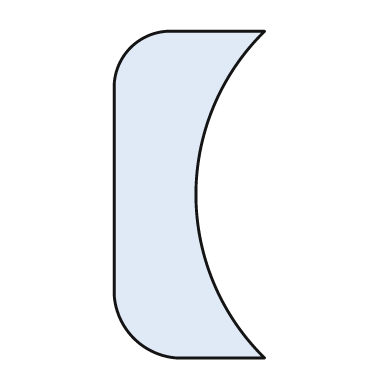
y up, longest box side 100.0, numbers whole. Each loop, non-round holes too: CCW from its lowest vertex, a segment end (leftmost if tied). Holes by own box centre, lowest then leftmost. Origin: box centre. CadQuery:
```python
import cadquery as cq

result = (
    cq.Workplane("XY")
    .moveTo(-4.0, -50.0)
    .lineTo(23.0, -50.0)
    .threePointArc((2.0, 0.0), (23.0, 50.0))
    .lineTo(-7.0, 50.0)
    .threePointArc((-18.0, 45.0), (-23.0, 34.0))
    .lineTo(-23.0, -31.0)
    .threePointArc((-17.0, -44.0), (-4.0, -50.0))
    .close()
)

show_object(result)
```